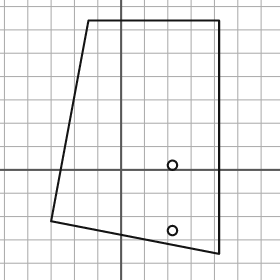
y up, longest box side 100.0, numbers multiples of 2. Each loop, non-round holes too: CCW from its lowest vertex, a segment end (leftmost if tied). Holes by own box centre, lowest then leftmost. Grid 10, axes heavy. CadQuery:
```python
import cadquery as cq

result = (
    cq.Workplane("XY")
    .moveTo(42.0, -36.0)
    .lineTo(42.0, 64.0)
    .lineTo(-14.0, 64.0)
    .lineTo(-30.0, -22.0)
    .close()
    .moveTo(22.0, -26.0)
    .circle(2.0)
    .moveTo(22.0, 2.0)
    .circle(2.0)
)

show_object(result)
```